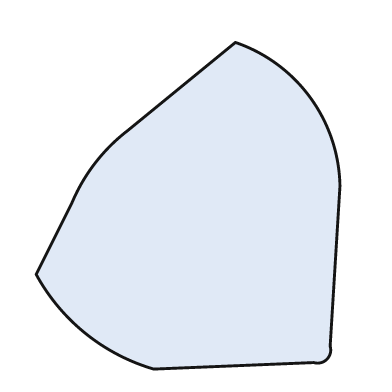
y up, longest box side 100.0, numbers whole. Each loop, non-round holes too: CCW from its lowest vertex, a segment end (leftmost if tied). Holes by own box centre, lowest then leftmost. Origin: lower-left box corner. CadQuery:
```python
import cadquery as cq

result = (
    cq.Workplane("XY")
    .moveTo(36.0, 0.0)
    .lineTo(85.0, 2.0)
    .threePointArc((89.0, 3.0), (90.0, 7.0))
    .lineTo(93.0, 56.0)
    .threePointArc((84.0, 83.0), (61.0, 100.0))
    .lineTo(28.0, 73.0)
    .threePointArc((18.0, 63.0), (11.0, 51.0))
    .lineTo(0.0, 29.0)
    .threePointArc((15.0, 11.0), (36.0, 0.0))
    .close()
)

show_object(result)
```